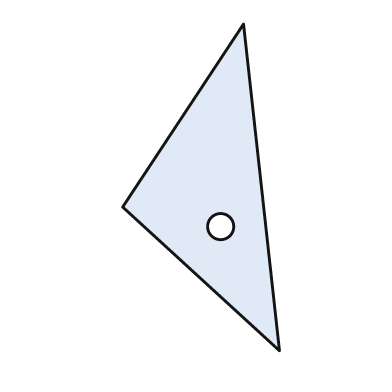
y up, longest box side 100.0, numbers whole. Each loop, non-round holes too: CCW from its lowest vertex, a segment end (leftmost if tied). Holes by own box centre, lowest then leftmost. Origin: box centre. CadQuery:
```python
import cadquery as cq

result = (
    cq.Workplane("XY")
    .moveTo(24.0, -50.0)
    .lineTo(13.0, 50.0)
    .lineTo(-24.0, -6.0)
    .close()
    .moveTo(6.0, -12.0)
    .circle(4.0)
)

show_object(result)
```